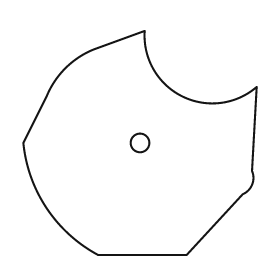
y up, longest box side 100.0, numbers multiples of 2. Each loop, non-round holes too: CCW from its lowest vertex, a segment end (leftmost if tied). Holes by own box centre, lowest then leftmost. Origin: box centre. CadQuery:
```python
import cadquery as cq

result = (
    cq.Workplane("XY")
    .moveTo(-18.0, -48.0)
    .lineTo(20.0, -48.0)
    .lineTo(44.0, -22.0)
    .threePointArc((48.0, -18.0), (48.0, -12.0))
    .lineTo(50.0, 24.0)
    .threePointArc((18.0, 20.0), (2.0, 48.0))
    .lineTo(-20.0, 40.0)
    .threePointArc((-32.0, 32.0), (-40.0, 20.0))
    .lineTo(-50.0, 0.0)
    .threePointArc((-40.0, -28.0), (-18.0, -48.0))
    .close()
    .moveTo(0.0, 0.0)
    .circle(4.0)
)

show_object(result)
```